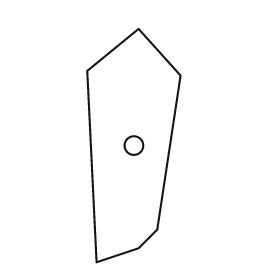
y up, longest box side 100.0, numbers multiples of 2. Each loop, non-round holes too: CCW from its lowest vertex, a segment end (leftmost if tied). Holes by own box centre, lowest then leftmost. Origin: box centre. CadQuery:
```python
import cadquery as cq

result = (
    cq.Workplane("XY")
    .moveTo(-16.0, -50.0)
    .lineTo(2.0, -44.0)
    .lineTo(10.0, -36.0)
    .lineTo(20.0, 30.0)
    .lineTo(2.0, 50.0)
    .lineTo(-20.0, 32.0)
    .close()
    .moveTo(0.0, 0.0)
    .circle(4.0)
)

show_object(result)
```